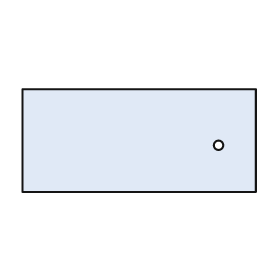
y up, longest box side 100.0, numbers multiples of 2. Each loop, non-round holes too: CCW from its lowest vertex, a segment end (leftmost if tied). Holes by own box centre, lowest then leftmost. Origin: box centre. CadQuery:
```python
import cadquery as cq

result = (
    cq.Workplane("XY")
    .moveTo(-50.0, -22.0)
    .lineTo(50.0, -22.0)
    .lineTo(50.0, 22.0)
    .lineTo(-50.0, 22.0)
    .close()
    .moveTo(34.0, -2.0)
    .circle(2.0)
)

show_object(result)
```